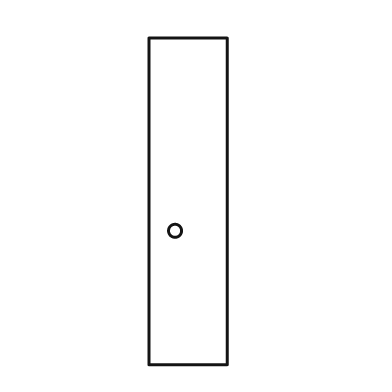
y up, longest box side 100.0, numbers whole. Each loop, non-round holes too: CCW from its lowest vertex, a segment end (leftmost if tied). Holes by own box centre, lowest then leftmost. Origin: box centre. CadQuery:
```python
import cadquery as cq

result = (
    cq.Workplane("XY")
    .moveTo(-12.0, -50.0)
    .lineTo(12.0, -50.0)
    .lineTo(12.0, 50.0)
    .lineTo(-12.0, 50.0)
    .close()
    .moveTo(-4.0, -9.0)
    .circle(2.0)
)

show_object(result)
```